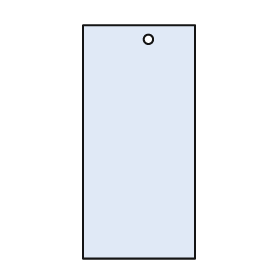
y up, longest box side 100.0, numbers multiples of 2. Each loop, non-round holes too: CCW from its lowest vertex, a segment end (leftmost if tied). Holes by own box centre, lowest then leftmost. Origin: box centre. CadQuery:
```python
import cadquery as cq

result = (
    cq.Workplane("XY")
    .moveTo(-24.0, -50.0)
    .lineTo(24.0, -50.0)
    .lineTo(24.0, 50.0)
    .lineTo(-24.0, 50.0)
    .close()
    .moveTo(4.0, 44.0)
    .circle(2.0)
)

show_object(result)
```